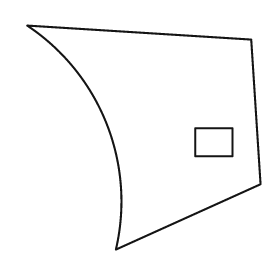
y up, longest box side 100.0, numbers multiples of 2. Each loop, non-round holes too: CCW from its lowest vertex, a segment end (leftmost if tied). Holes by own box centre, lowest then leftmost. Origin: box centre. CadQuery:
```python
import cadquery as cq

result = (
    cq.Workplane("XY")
    .moveTo(-12.0, -48.0)
    .lineTo(50.0, -20.0)
    .lineTo(46.0, 42.0)
    .lineTo(-50.0, 48.0)
    .threePointArc((-16.0, 6.0), (-12.0, -48.0))
    .close()
    .moveTo(22.0, -8.0)
    .lineTo(38.0, -8.0)
    .lineTo(38.0, 4.0)
    .lineTo(22.0, 4.0)
    .close()
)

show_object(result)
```